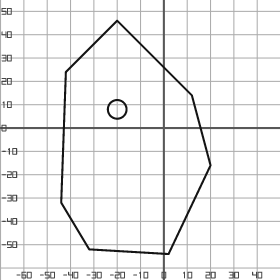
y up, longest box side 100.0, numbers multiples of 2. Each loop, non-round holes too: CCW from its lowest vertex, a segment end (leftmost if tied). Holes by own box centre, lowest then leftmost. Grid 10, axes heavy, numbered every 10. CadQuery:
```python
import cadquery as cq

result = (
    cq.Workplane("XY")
    .moveTo(2.0, -54.0)
    .lineTo(20.0, -16.0)
    .lineTo(12.0, 14.0)
    .lineTo(-20.0, 46.0)
    .lineTo(-42.0, 24.0)
    .lineTo(-44.0, -32.0)
    .lineTo(-32.0, -52.0)
    .close()
    .moveTo(-20.0, 8.0)
    .circle(4.0)
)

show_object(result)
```